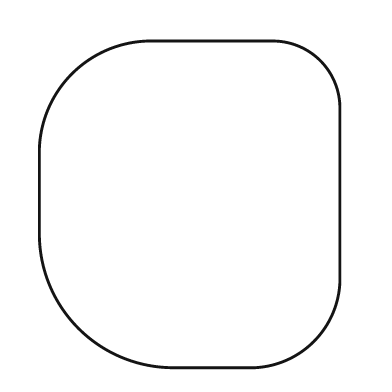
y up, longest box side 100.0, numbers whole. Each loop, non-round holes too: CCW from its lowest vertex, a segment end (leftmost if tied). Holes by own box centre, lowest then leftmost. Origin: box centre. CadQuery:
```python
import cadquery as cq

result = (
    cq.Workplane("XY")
    .moveTo(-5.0, -50.0)
    .lineTo(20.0, -50.0)
    .threePointArc((38.0, -42.0), (46.0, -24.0))
    .lineTo(46.0, 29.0)
    .threePointArc((40.0, 44.0), (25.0, 50.0))
    .lineTo(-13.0, 50.0)
    .threePointArc((-36.0, 40.0), (-46.0, 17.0))
    .lineTo(-46.0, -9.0)
    .threePointArc((-34.0, -38.0), (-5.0, -50.0))
    .close()
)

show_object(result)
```